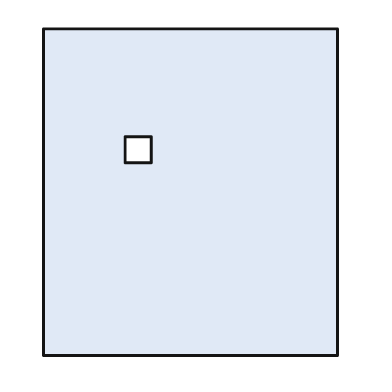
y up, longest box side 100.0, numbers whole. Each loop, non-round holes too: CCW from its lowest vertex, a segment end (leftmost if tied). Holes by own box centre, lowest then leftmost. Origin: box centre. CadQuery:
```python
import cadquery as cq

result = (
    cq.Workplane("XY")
    .moveTo(-45.0, -50.0)
    .lineTo(45.0, -50.0)
    .lineTo(45.0, 50.0)
    .lineTo(-45.0, 50.0)
    .close()
    .moveTo(-20.0, 9.0)
    .lineTo(-12.0, 9.0)
    .lineTo(-12.0, 17.0)
    .lineTo(-20.0, 17.0)
    .close()
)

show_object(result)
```